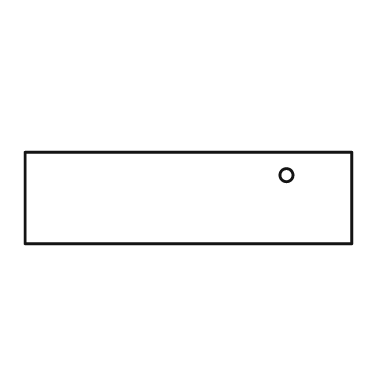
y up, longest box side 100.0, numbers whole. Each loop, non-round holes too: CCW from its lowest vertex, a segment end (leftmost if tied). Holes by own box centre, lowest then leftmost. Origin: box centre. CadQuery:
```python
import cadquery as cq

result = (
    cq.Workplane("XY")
    .moveTo(-50.0, -14.0)
    .lineTo(50.0, -14.0)
    .lineTo(50.0, 14.0)
    .lineTo(-50.0, 14.0)
    .close()
    .moveTo(30.0, 7.0)
    .circle(2.0)
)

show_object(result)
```